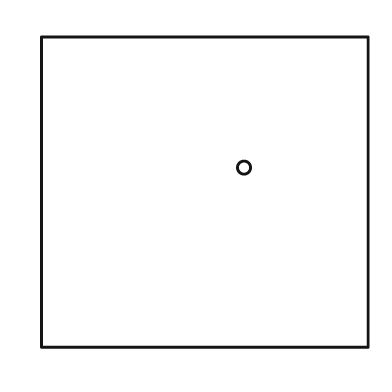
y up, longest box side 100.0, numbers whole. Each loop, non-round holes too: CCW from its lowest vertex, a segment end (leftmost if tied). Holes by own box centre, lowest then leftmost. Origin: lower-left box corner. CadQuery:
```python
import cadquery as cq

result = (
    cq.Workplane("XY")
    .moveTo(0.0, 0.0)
    .lineTo(100.0, 0.0)
    .lineTo(100.0, 95.0)
    .lineTo(0.0, 95.0)
    .close()
    .moveTo(62.0, 55.0)
    .circle(2.0)
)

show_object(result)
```